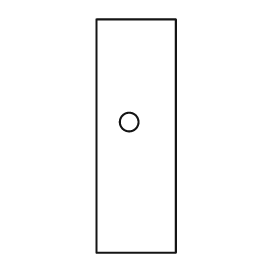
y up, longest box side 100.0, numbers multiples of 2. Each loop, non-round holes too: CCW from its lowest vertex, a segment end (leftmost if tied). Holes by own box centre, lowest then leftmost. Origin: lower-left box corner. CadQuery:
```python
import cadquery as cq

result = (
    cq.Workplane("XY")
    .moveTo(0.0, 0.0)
    .lineTo(34.0, 0.0)
    .lineTo(34.0, 100.0)
    .lineTo(0.0, 100.0)
    .close()
    .moveTo(14.0, 56.0)
    .circle(4.0)
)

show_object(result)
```